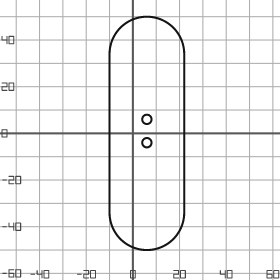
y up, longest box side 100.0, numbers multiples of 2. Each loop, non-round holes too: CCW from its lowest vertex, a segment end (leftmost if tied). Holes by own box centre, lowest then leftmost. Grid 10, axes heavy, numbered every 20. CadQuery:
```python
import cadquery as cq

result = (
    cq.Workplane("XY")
    .moveTo(-10.0, -34.0)
    .threePointArc((6.0, -50.0), (22.0, -34.0))
    .lineTo(22.0, 34.0)
    .threePointArc((6.0, 50.0), (-10.0, 34.0))
    .close()
    .moveTo(6.0, -4.0)
    .circle(2.0)
    .moveTo(6.0, 6.0)
    .circle(2.0)
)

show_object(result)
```